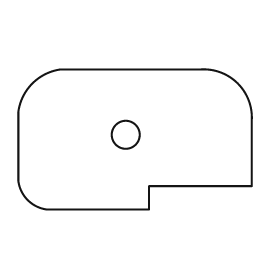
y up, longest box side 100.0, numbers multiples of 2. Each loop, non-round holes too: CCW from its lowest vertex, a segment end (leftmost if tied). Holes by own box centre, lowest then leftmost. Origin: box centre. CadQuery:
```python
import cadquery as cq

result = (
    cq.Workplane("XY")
    .moveTo(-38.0, -30.0)
    .lineTo(6.0, -30.0)
    .lineTo(6.0, -20.0)
    .lineTo(50.0, -20.0)
    .lineTo(50.0, 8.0)
    .threePointArc((44.0, 24.0), (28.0, 30.0))
    .lineTo(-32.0, 30.0)
    .threePointArc((-44.0, 24.0), (-50.0, 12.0))
    .lineTo(-50.0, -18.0)
    .threePointArc((-46.0, -26.0), (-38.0, -30.0))
    .close()
    .moveTo(-4.0, 2.0)
    .circle(6.0)
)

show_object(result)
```